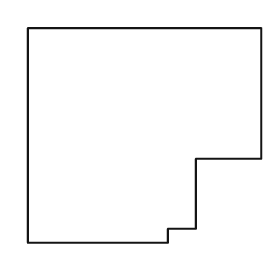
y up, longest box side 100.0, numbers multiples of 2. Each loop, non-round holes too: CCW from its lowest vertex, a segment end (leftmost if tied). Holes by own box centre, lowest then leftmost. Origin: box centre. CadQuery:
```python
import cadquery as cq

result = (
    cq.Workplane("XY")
    .moveTo(-50.0, -46.0)
    .lineTo(10.0, -46.0)
    .lineTo(10.0, -40.0)
    .lineTo(22.0, -40.0)
    .lineTo(22.0, -10.0)
    .lineTo(50.0, -10.0)
    .lineTo(50.0, 46.0)
    .lineTo(-50.0, 46.0)
    .close()
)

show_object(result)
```